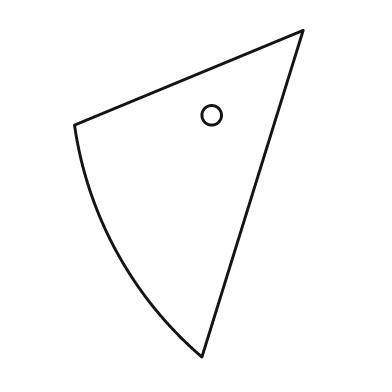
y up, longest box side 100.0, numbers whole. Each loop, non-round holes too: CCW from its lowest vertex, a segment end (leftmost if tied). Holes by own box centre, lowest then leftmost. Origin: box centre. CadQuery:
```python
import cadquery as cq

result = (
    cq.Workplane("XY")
    .moveTo(4.0, -50.0)
    .lineTo(35.0, 50.0)
    .lineTo(-35.0, 21.0)
    .threePointArc((-22.0, -18.0), (4.0, -50.0))
    .close()
    .moveTo(7.0, 24.0)
    .circle(3.0)
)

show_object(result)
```